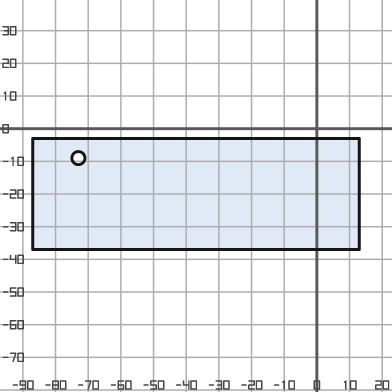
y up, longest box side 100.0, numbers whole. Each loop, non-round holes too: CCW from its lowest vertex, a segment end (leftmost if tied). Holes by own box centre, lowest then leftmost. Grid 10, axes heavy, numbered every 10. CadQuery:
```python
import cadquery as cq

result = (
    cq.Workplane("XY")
    .moveTo(-87.0, -37.0)
    .lineTo(13.0, -37.0)
    .lineTo(13.0, -3.0)
    .lineTo(-87.0, -3.0)
    .close()
    .moveTo(-73.0, -9.0)
    .circle(2.0)
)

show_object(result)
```